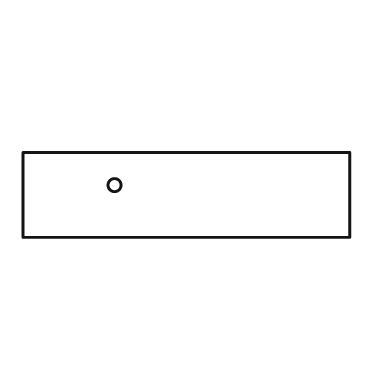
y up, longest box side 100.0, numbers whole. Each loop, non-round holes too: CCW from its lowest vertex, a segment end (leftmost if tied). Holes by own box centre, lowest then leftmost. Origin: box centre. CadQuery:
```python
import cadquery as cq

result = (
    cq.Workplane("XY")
    .moveTo(-50.0, -13.0)
    .lineTo(50.0, -13.0)
    .lineTo(50.0, 13.0)
    .lineTo(-50.0, 13.0)
    .close()
    .moveTo(-22.0, 3.0)
    .circle(2.0)
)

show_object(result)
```